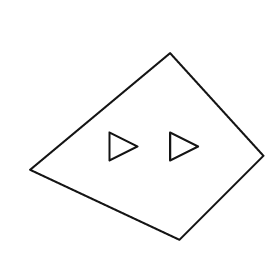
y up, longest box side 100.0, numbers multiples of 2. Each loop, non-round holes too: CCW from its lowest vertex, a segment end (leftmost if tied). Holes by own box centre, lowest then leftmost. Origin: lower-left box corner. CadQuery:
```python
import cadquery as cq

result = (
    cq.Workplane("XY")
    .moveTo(64.0, 0.0)
    .lineTo(100.0, 36.0)
    .lineTo(60.0, 80.0)
    .lineTo(0.0, 30.0)
    .close()
    .moveTo(34.0, 34.0)
    .lineTo(46.0, 40.0)
    .lineTo(34.0, 46.0)
    .close()
    .moveTo(60.0, 34.0)
    .lineTo(72.0, 40.0)
    .lineTo(60.0, 46.0)
    .close()
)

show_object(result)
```